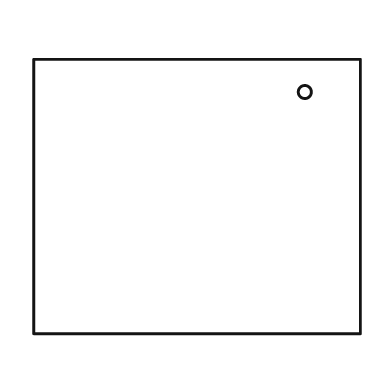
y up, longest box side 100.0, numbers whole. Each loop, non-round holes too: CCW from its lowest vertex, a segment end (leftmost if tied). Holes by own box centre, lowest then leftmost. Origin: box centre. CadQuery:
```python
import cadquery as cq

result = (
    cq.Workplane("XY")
    .moveTo(-50.0, -42.0)
    .lineTo(50.0, -42.0)
    .lineTo(50.0, 42.0)
    .lineTo(-50.0, 42.0)
    .close()
    .moveTo(33.0, 32.0)
    .circle(2.0)
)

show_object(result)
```